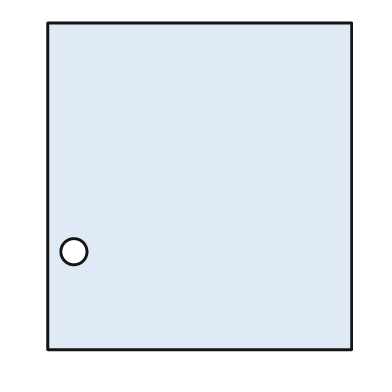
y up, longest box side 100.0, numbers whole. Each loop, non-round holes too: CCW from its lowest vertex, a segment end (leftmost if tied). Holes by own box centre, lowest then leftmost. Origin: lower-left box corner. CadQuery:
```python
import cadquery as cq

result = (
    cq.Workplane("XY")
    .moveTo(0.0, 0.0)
    .lineTo(93.0, 0.0)
    .lineTo(93.0, 100.0)
    .lineTo(0.0, 100.0)
    .close()
    .moveTo(8.0, 30.0)
    .circle(4.0)
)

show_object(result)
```